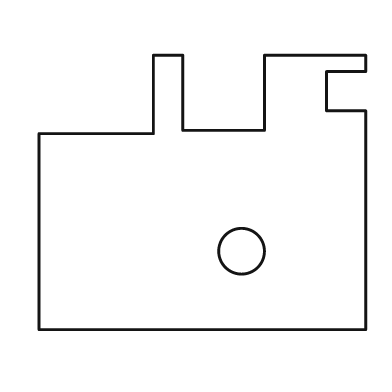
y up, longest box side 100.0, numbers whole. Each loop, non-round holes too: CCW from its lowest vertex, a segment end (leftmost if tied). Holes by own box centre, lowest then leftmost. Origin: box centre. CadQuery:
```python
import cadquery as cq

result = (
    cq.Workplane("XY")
    .moveTo(-50.0, -42.0)
    .lineTo(50.0, -42.0)
    .lineTo(50.0, 25.0)
    .lineTo(38.0, 25.0)
    .lineTo(38.0, 37.0)
    .lineTo(50.0, 37.0)
    .lineTo(50.0, 42.0)
    .lineTo(19.0, 42.0)
    .lineTo(19.0, 19.0)
    .lineTo(-6.0, 19.0)
    .lineTo(-6.0, 42.0)
    .lineTo(-15.0, 42.0)
    .lineTo(-15.0, 18.0)
    .lineTo(-50.0, 18.0)
    .close()
    .moveTo(12.0, -18.0)
    .circle(7.0)
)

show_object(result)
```